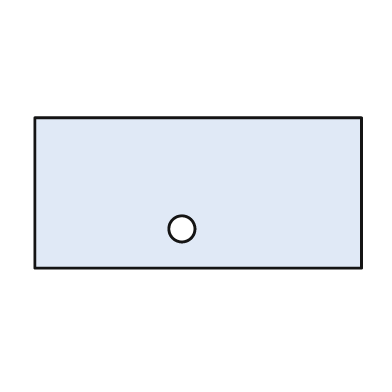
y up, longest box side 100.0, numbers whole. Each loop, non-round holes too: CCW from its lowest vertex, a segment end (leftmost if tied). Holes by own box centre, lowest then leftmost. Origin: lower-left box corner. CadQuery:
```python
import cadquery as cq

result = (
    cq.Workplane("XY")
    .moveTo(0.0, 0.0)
    .lineTo(100.0, 0.0)
    .lineTo(100.0, 46.0)
    .lineTo(0.0, 46.0)
    .close()
    .moveTo(45.0, 12.0)
    .circle(4.0)
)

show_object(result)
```